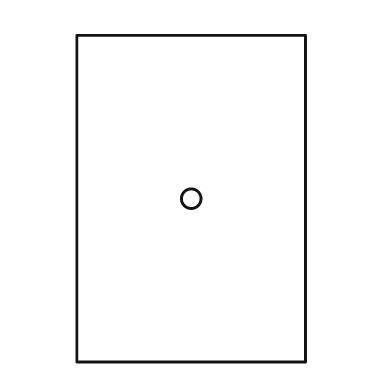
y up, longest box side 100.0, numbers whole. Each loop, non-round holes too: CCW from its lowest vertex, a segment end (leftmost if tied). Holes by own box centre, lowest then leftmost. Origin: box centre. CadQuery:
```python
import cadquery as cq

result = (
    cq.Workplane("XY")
    .moveTo(-35.0, -50.0)
    .lineTo(35.0, -50.0)
    .lineTo(35.0, 50.0)
    .lineTo(-35.0, 50.0)
    .close()
    .moveTo(0.0, 0.0)
    .circle(3.0)
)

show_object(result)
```